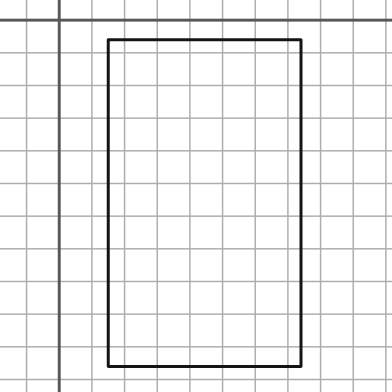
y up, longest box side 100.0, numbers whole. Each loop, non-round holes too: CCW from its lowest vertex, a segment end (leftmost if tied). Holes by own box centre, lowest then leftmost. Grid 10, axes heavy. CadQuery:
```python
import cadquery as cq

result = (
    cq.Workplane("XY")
    .moveTo(15.0, -106.0)
    .lineTo(74.0, -106.0)
    .lineTo(74.0, -6.0)
    .lineTo(15.0, -6.0)
    .close()
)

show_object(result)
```